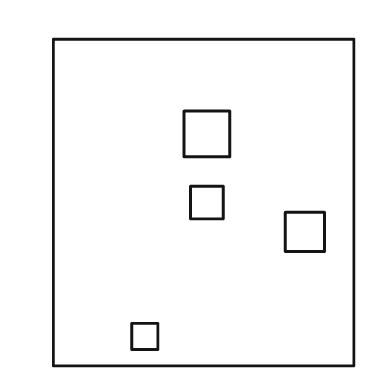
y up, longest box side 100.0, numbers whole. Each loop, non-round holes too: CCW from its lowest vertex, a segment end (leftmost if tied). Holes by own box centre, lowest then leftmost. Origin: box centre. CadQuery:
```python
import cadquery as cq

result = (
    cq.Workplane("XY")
    .moveTo(-46.0, -50.0)
    .lineTo(46.0, -50.0)
    .lineTo(46.0, 50.0)
    .lineTo(-46.0, 50.0)
    .close()
    .moveTo(-22.0, -45.0)
    .lineTo(-14.0, -45.0)
    .lineTo(-14.0, -37.0)
    .lineTo(-22.0, -37.0)
    .close()
    .moveTo(25.0, -15.0)
    .lineTo(37.0, -15.0)
    .lineTo(37.0, -3.0)
    .lineTo(25.0, -3.0)
    .close()
    .moveTo(-4.0, -5.0)
    .lineTo(6.0, -5.0)
    .lineTo(6.0, 5.0)
    .lineTo(-4.0, 5.0)
    .close()
    .moveTo(-6.0, 14.0)
    .lineTo(8.0, 14.0)
    .lineTo(8.0, 28.0)
    .lineTo(-6.0, 28.0)
    .close()
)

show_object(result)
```